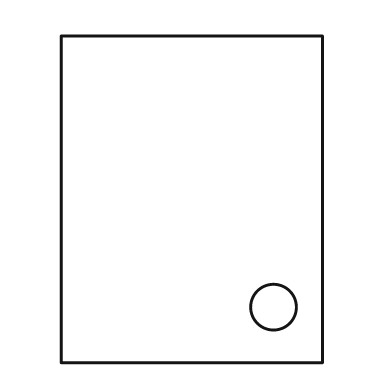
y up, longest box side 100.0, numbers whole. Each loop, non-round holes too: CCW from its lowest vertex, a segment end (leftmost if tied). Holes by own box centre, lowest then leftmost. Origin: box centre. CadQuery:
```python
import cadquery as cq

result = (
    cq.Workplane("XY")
    .moveTo(-40.0, -50.0)
    .lineTo(40.0, -50.0)
    .lineTo(40.0, 50.0)
    .lineTo(-40.0, 50.0)
    .close()
    .moveTo(25.0, -33.0)
    .circle(7.0)
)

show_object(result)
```